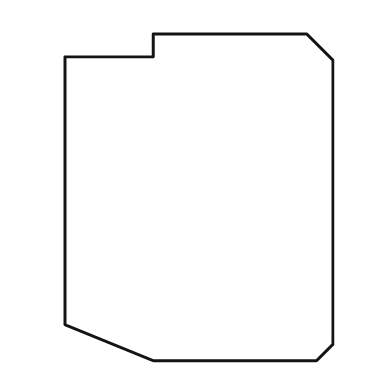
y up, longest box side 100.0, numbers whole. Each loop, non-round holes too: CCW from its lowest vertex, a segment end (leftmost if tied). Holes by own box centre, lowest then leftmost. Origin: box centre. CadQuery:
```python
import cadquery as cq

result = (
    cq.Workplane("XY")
    .moveTo(-14.0, -50.0)
    .lineTo(36.0, -50.0)
    .lineTo(41.0, -45.0)
    .lineTo(41.0, 42.0)
    .lineTo(33.0, 50.0)
    .lineTo(-14.0, 50.0)
    .lineTo(-14.0, 43.0)
    .lineTo(-41.0, 43.0)
    .lineTo(-41.0, -39.0)
    .close()
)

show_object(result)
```